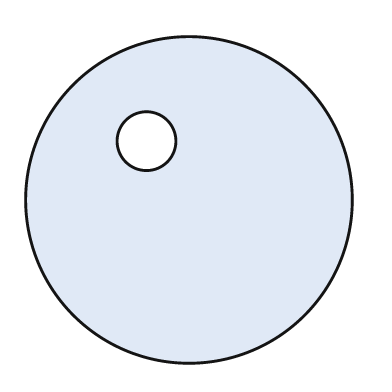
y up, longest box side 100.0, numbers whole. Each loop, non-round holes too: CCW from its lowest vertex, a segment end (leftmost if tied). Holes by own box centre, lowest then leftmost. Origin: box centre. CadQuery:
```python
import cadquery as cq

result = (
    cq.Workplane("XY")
    .moveTo(0.0, 0.0)
    .circle(50.0)
    .moveTo(-13.0, 18.0)
    .circle(9.0)
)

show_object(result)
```